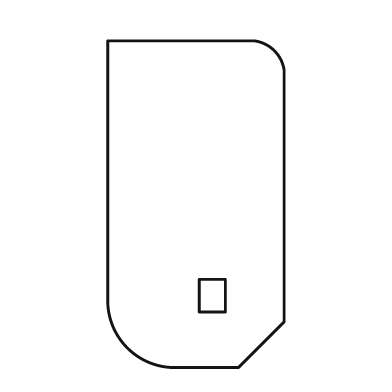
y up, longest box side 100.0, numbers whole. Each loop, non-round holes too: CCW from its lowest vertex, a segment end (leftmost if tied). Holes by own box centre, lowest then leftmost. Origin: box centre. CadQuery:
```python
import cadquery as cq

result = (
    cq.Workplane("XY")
    .moveTo(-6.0, -50.0)
    .lineTo(13.0, -50.0)
    .lineTo(27.0, -36.0)
    .lineTo(27.0, 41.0)
    .threePointArc((24.0, 47.0), (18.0, 50.0))
    .lineTo(-27.0, 50.0)
    .lineTo(-27.0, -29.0)
    .threePointArc((-21.0, -44.0), (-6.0, -50.0))
    .close()
    .moveTo(1.0, -33.0)
    .lineTo(9.0, -33.0)
    .lineTo(9.0, -23.0)
    .lineTo(1.0, -23.0)
    .close()
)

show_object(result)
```